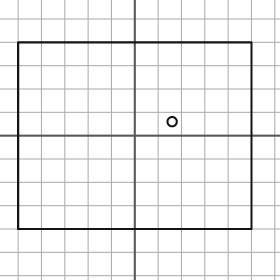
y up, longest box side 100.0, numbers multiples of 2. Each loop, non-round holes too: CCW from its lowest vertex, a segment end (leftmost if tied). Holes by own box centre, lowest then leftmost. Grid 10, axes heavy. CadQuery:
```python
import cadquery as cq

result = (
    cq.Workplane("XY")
    .moveTo(-50.0, -40.0)
    .lineTo(50.0, -40.0)
    .lineTo(50.0, 40.0)
    .lineTo(-50.0, 40.0)
    .close()
    .moveTo(16.0, 6.0)
    .circle(2.0)
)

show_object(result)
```